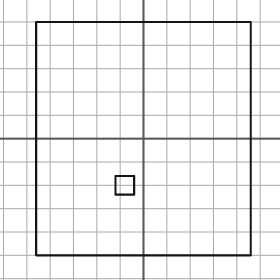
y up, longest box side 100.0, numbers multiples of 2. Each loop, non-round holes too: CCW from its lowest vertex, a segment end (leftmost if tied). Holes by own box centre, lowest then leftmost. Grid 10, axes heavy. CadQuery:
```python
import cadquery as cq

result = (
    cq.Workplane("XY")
    .moveTo(-46.0, -50.0)
    .lineTo(46.0, -50.0)
    .lineTo(46.0, 50.0)
    .lineTo(-46.0, 50.0)
    .close()
    .moveTo(-12.0, -24.0)
    .lineTo(-4.0, -24.0)
    .lineTo(-4.0, -16.0)
    .lineTo(-12.0, -16.0)
    .close()
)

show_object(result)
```